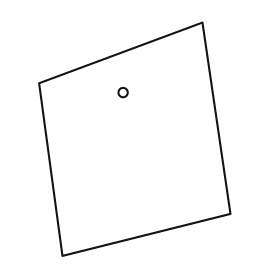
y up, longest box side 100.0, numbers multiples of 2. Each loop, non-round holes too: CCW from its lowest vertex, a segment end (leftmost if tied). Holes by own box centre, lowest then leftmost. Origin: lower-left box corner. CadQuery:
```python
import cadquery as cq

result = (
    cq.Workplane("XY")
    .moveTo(10.0, 0.0)
    .lineTo(82.0, 18.0)
    .lineTo(70.0, 100.0)
    .lineTo(0.0, 74.0)
    .close()
    .moveTo(36.0, 70.0)
    .circle(2.0)
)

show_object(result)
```